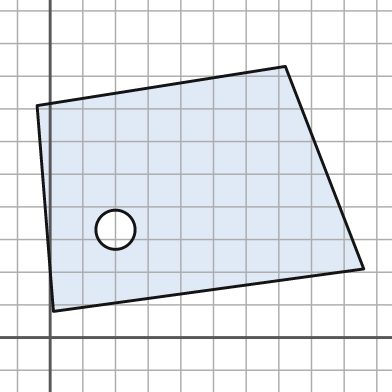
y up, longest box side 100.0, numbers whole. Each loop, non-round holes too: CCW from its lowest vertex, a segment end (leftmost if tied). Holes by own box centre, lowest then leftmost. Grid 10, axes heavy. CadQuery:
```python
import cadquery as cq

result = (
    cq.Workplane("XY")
    .moveTo(1.0, 8.0)
    .lineTo(96.0, 21.0)
    .lineTo(72.0, 83.0)
    .lineTo(-4.0, 71.0)
    .close()
    .moveTo(20.0, 33.0)
    .circle(6.0)
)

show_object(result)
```